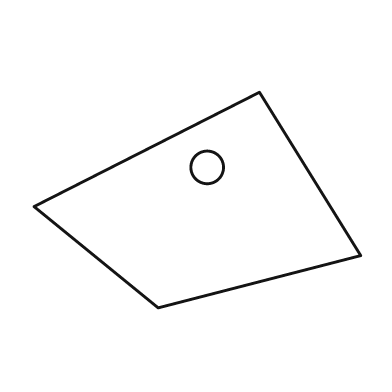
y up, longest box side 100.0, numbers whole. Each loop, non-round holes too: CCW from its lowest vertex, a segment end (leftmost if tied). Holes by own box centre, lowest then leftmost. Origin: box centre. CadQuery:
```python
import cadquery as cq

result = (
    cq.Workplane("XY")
    .moveTo(-12.0, -33.0)
    .lineTo(50.0, -17.0)
    .lineTo(19.0, 33.0)
    .lineTo(-50.0, -2.0)
    .close()
    .moveTo(3.0, 10.0)
    .circle(5.0)
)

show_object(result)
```